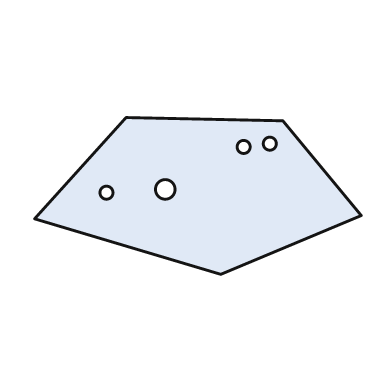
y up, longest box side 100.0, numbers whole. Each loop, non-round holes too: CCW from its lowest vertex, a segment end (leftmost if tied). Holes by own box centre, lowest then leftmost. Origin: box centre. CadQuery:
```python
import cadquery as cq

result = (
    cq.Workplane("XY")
    .moveTo(7.0, -24.0)
    .lineTo(50.0, -6.0)
    .lineTo(26.0, 23.0)
    .lineTo(-22.0, 24.0)
    .lineTo(-50.0, -7.0)
    .close()
    .moveTo(-28.0, 1.0)
    .circle(2.0)
    .moveTo(-10.0, 2.0)
    .circle(3.0)
    .moveTo(14.0, 15.0)
    .circle(2.0)
    .moveTo(22.0, 16.0)
    .circle(2.0)
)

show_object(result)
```